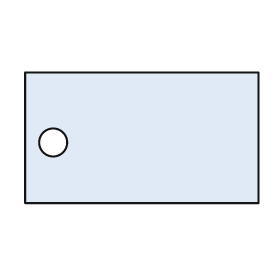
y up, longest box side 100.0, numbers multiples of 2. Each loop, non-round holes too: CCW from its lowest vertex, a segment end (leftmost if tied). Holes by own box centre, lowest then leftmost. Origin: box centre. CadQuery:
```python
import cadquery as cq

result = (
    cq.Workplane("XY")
    .moveTo(-50.0, -28.0)
    .lineTo(50.0, -28.0)
    .lineTo(50.0, 28.0)
    .lineTo(-50.0, 28.0)
    .close()
    .moveTo(-38.0, -2.0)
    .circle(6.0)
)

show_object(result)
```